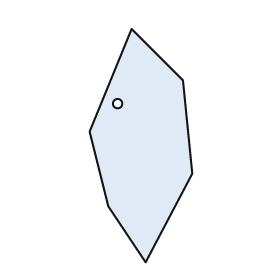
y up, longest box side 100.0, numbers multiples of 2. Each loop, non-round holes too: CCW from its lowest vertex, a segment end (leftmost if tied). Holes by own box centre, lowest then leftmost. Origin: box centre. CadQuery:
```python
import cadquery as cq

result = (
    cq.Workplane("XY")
    .moveTo(2.0, -50.0)
    .lineTo(22.0, -12.0)
    .lineTo(18.0, 28.0)
    .lineTo(-4.0, 50.0)
    .lineTo(-22.0, 6.0)
    .lineTo(-14.0, -26.0)
    .close()
    .moveTo(-10.0, 18.0)
    .circle(2.0)
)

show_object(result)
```